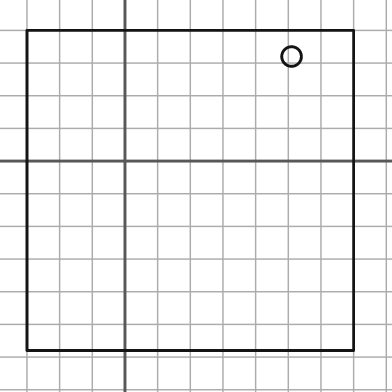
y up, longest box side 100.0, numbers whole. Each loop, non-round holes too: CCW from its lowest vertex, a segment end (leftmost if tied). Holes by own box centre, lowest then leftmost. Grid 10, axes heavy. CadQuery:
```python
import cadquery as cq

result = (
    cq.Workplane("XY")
    .moveTo(-30.0, -58.0)
    .lineTo(70.0, -58.0)
    .lineTo(70.0, 40.0)
    .lineTo(-30.0, 40.0)
    .close()
    .moveTo(51.0, 32.0)
    .circle(3.0)
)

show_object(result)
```